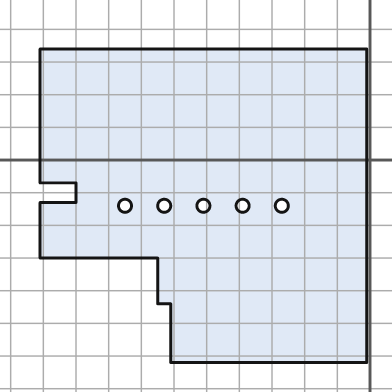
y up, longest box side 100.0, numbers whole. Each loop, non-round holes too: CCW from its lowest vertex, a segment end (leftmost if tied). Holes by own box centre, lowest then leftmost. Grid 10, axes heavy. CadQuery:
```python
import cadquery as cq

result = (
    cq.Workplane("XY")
    .moveTo(-61.0, -62.0)
    .lineTo(-1.0, -62.0)
    .lineTo(-1.0, 34.0)
    .lineTo(-101.0, 34.0)
    .lineTo(-101.0, -7.0)
    .lineTo(-90.0, -7.0)
    .lineTo(-90.0, -13.0)
    .lineTo(-101.0, -13.0)
    .lineTo(-101.0, -30.0)
    .lineTo(-65.0, -30.0)
    .lineTo(-65.0, -44.0)
    .lineTo(-61.0, -44.0)
    .close()
    .moveTo(-75.0, -14.0)
    .circle(2.0)
    .moveTo(-63.0, -14.0)
    .circle(2.0)
    .moveTo(-51.0, -14.0)
    .circle(2.0)
    .moveTo(-39.0, -14.0)
    .circle(2.0)
    .moveTo(-27.0, -14.0)
    .circle(2.0)
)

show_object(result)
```